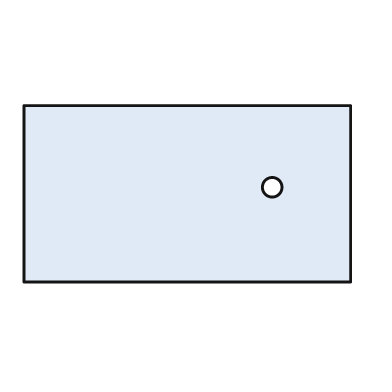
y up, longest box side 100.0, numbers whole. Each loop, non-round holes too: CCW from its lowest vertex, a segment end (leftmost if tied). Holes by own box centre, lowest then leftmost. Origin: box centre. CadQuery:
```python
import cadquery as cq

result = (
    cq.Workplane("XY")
    .moveTo(-50.0, -27.0)
    .lineTo(50.0, -27.0)
    .lineTo(50.0, 27.0)
    .lineTo(-50.0, 27.0)
    .close()
    .moveTo(26.0, 2.0)
    .circle(3.0)
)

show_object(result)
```